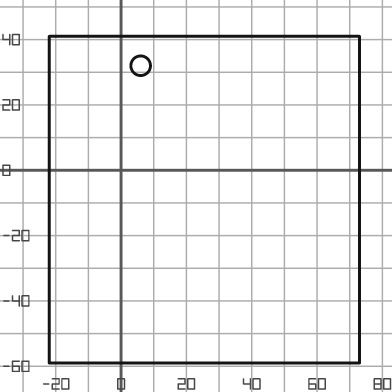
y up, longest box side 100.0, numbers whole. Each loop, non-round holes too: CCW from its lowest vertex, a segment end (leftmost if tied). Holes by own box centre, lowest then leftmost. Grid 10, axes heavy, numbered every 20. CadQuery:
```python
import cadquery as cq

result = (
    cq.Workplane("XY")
    .moveTo(-22.0, -59.0)
    .lineTo(73.0, -59.0)
    .lineTo(73.0, 41.0)
    .lineTo(-22.0, 41.0)
    .close()
    .moveTo(6.0, 32.0)
    .circle(3.0)
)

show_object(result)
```